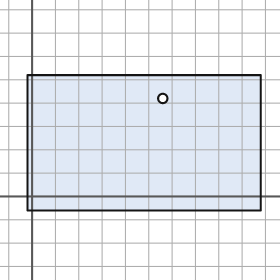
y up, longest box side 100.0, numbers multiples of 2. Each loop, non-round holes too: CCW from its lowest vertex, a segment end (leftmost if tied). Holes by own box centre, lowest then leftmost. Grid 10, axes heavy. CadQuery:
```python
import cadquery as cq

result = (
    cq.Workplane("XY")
    .moveTo(-2.0, -6.0)
    .lineTo(98.0, -6.0)
    .lineTo(98.0, 52.0)
    .lineTo(-2.0, 52.0)
    .close()
    .moveTo(56.0, 42.0)
    .circle(2.0)
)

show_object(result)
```